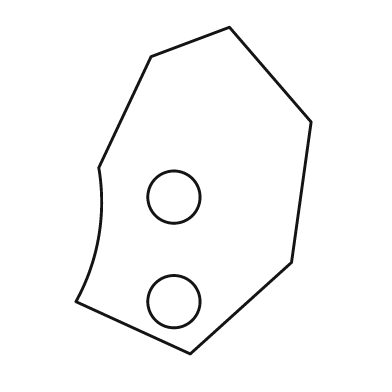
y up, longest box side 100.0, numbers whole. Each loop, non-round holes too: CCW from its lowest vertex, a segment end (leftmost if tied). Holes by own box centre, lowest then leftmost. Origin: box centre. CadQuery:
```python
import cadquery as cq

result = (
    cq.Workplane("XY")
    .moveTo(-1.0, -50.0)
    .lineTo(30.0, -22.0)
    .lineTo(36.0, 21.0)
    .lineTo(11.0, 50.0)
    .lineTo(-13.0, 41.0)
    .lineTo(-29.0, 7.0)
    .threePointArc((-29.0, -14.0), (-36.0, -34.0))
    .close()
    .moveTo(-6.0, -34.0)
    .circle(8.0)
    .moveTo(-6.0, -2.0)
    .circle(8.0)
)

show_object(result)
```